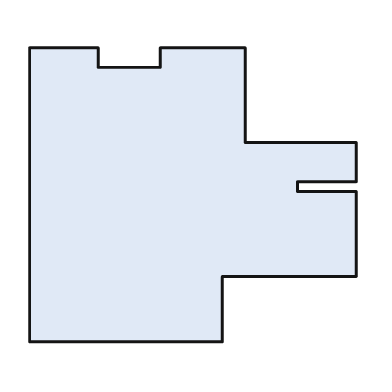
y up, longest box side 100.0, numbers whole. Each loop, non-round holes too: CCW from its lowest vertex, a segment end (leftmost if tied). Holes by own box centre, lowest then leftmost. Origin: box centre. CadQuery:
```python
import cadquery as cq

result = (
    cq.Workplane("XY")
    .moveTo(-50.0, -45.0)
    .lineTo(9.0, -45.0)
    .lineTo(9.0, -25.0)
    .lineTo(50.0, -25.0)
    .lineTo(50.0, 1.0)
    .lineTo(32.0, 1.0)
    .lineTo(32.0, 4.0)
    .lineTo(50.0, 4.0)
    .lineTo(50.0, 16.0)
    .lineTo(16.0, 16.0)
    .lineTo(16.0, 45.0)
    .lineTo(-10.0, 45.0)
    .lineTo(-10.0, 39.0)
    .lineTo(-29.0, 39.0)
    .lineTo(-29.0, 45.0)
    .lineTo(-50.0, 45.0)
    .close()
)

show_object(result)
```